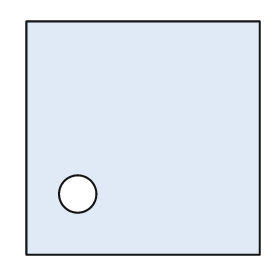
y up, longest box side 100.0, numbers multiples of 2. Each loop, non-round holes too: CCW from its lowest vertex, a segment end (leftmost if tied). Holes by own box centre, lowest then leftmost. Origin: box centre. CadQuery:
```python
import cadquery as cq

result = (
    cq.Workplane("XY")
    .moveTo(-50.0, -50.0)
    .lineTo(50.0, -50.0)
    .lineTo(50.0, 50.0)
    .lineTo(-50.0, 50.0)
    .close()
    .moveTo(-28.0, -24.0)
    .circle(8.0)
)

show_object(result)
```